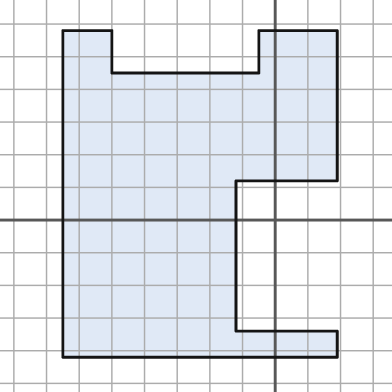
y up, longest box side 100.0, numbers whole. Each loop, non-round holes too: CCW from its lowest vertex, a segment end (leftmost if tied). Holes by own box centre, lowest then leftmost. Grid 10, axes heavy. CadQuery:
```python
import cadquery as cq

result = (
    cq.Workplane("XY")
    .moveTo(-65.0, -42.0)
    .lineTo(19.0, -42.0)
    .lineTo(19.0, -34.0)
    .lineTo(-12.0, -34.0)
    .lineTo(-12.0, 12.0)
    .lineTo(19.0, 12.0)
    .lineTo(19.0, 58.0)
    .lineTo(-5.0, 58.0)
    .lineTo(-5.0, 45.0)
    .lineTo(-50.0, 45.0)
    .lineTo(-50.0, 58.0)
    .lineTo(-65.0, 58.0)
    .close()
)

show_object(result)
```